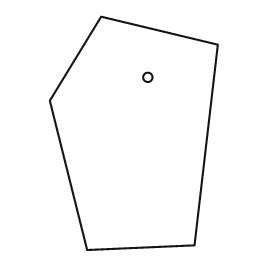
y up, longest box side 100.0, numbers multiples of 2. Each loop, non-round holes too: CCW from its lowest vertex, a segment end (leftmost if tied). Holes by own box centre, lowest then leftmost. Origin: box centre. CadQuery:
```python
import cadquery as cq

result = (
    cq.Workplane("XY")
    .moveTo(-20.0, -50.0)
    .lineTo(26.0, -48.0)
    .lineTo(36.0, 38.0)
    .lineTo(-14.0, 50.0)
    .lineTo(-36.0, 14.0)
    .close()
    .moveTo(6.0, 24.0)
    .circle(2.0)
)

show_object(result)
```